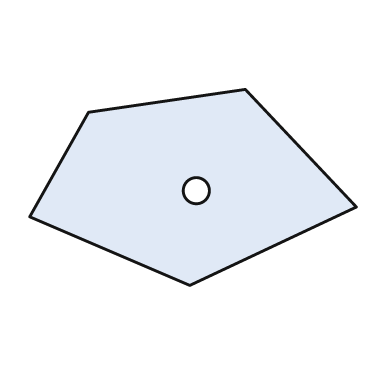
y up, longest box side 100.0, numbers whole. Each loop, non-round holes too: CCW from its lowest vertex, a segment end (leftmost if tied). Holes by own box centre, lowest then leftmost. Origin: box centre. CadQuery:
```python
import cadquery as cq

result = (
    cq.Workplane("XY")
    .moveTo(-1.0, -30.0)
    .lineTo(50.0, -6.0)
    .lineTo(16.0, 30.0)
    .lineTo(-32.0, 23.0)
    .lineTo(-50.0, -9.0)
    .close()
    .moveTo(1.0, -1.0)
    .circle(4.0)
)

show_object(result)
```